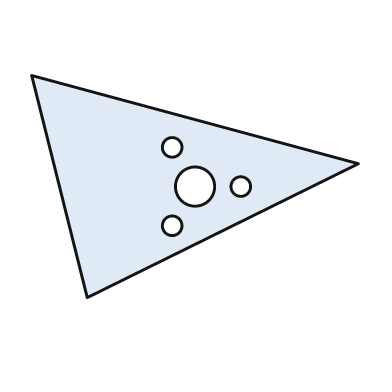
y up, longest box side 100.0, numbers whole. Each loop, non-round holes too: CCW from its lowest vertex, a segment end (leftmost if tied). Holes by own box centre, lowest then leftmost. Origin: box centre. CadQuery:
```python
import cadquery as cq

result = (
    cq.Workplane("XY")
    .moveTo(-33.0, -34.0)
    .lineTo(50.0, 7.0)
    .lineTo(-50.0, 34.0)
    .close()
    .moveTo(-7.0, -12.0)
    .circle(3.0)
    .moveTo(0.0, 0.0)
    .circle(6.0)
    .moveTo(14.0, 0.0)
    .circle(3.0)
    .moveTo(-7.0, 12.0)
    .circle(3.0)
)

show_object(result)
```